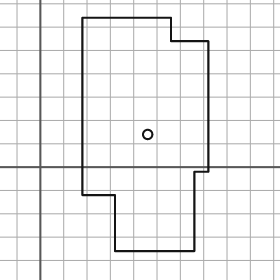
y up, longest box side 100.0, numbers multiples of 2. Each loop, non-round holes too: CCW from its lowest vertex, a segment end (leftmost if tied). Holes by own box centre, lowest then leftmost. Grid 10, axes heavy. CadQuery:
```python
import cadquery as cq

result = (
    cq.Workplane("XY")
    .moveTo(32.0, -36.0)
    .lineTo(66.0, -36.0)
    .lineTo(66.0, -2.0)
    .lineTo(72.0, -2.0)
    .lineTo(72.0, 54.0)
    .lineTo(56.0, 54.0)
    .lineTo(56.0, 64.0)
    .lineTo(18.0, 64.0)
    .lineTo(18.0, -12.0)
    .lineTo(32.0, -12.0)
    .close()
    .moveTo(46.0, 14.0)
    .circle(2.0)
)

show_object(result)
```